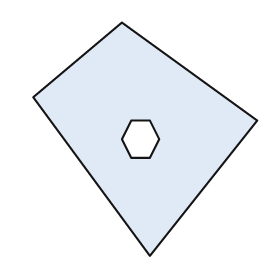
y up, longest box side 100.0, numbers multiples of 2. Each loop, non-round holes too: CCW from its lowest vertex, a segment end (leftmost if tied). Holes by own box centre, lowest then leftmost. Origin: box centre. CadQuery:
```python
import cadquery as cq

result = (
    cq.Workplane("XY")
    .moveTo(2.0, -50.0)
    .lineTo(48.0, 8.0)
    .lineTo(-10.0, 50.0)
    .lineTo(-48.0, 18.0)
    .close()
    .moveTo(-6.0, -8.0)
    .lineTo(2.0, -8.0)
    .lineTo(6.0, 0.0)
    .lineTo(2.0, 8.0)
    .lineTo(-6.0, 8.0)
    .lineTo(-10.0, 0.0)
    .close()
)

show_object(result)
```